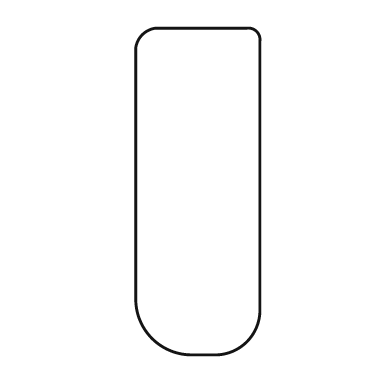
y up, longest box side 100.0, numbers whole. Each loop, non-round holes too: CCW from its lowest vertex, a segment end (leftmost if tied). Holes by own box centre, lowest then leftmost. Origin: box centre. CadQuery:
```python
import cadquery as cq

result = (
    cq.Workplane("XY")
    .moveTo(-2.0, -50.0)
    .lineTo(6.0, -50.0)
    .threePointArc((15.0, -46.0), (19.0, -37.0))
    .lineTo(19.0, 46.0)
    .threePointArc((18.0, 49.0), (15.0, 50.0))
    .lineTo(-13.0, 50.0)
    .threePointArc((-17.0, 48.0), (-19.0, 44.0))
    .lineTo(-19.0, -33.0)
    .threePointArc((-14.0, -45.0), (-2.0, -50.0))
    .close()
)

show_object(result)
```